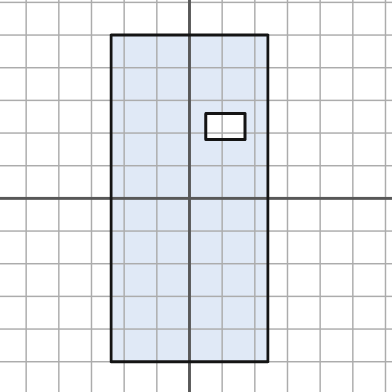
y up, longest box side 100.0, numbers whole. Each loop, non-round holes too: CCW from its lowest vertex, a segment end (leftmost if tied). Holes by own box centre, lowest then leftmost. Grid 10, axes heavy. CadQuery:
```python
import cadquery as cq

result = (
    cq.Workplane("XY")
    .moveTo(-24.0, -50.0)
    .lineTo(24.0, -50.0)
    .lineTo(24.0, 50.0)
    .lineTo(-24.0, 50.0)
    .close()
    .moveTo(5.0, 18.0)
    .lineTo(17.0, 18.0)
    .lineTo(17.0, 26.0)
    .lineTo(5.0, 26.0)
    .close()
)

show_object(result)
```